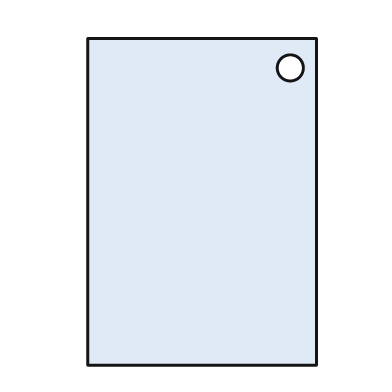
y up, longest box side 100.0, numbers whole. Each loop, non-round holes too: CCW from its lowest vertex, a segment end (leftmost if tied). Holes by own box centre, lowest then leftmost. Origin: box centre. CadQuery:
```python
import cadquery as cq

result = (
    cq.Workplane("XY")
    .moveTo(-35.0, -50.0)
    .lineTo(35.0, -50.0)
    .lineTo(35.0, 50.0)
    .lineTo(-35.0, 50.0)
    .close()
    .moveTo(27.0, 41.0)
    .circle(4.0)
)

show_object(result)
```